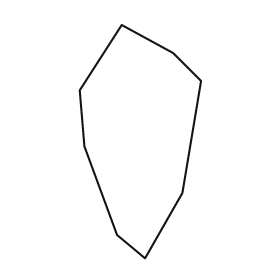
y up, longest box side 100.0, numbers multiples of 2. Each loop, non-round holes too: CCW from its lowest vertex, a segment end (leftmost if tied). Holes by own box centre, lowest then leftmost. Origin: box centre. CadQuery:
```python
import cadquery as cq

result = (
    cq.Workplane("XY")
    .moveTo(2.0, -50.0)
    .lineTo(18.0, -22.0)
    .lineTo(26.0, 26.0)
    .lineTo(14.0, 38.0)
    .lineTo(-8.0, 50.0)
    .lineTo(-26.0, 22.0)
    .lineTo(-24.0, -2.0)
    .lineTo(-10.0, -40.0)
    .close()
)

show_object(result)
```